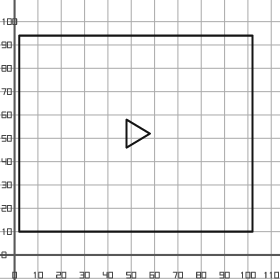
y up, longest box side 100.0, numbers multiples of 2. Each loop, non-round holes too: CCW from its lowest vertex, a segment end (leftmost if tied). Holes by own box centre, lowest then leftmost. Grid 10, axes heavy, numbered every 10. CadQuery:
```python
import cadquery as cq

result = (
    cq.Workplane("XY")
    .moveTo(2.0, 10.0)
    .lineTo(102.0, 10.0)
    .lineTo(102.0, 94.0)
    .lineTo(2.0, 94.0)
    .close()
    .moveTo(48.0, 46.0)
    .lineTo(58.0, 52.0)
    .lineTo(48.0, 58.0)
    .close()
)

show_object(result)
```